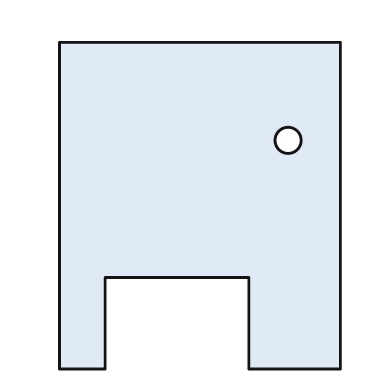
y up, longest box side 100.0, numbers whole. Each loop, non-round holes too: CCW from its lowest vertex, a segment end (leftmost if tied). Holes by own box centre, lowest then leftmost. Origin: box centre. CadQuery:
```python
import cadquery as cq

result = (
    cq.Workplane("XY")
    .moveTo(-43.0, -50.0)
    .lineTo(-29.0, -50.0)
    .lineTo(-29.0, -22.0)
    .lineTo(15.0, -22.0)
    .lineTo(15.0, -50.0)
    .lineTo(43.0, -50.0)
    .lineTo(43.0, 50.0)
    .lineTo(-43.0, 50.0)
    .close()
    .moveTo(27.0, 20.0)
    .circle(4.0)
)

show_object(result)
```